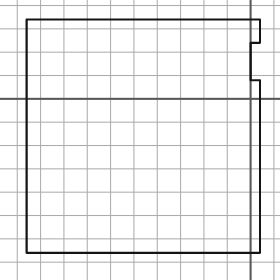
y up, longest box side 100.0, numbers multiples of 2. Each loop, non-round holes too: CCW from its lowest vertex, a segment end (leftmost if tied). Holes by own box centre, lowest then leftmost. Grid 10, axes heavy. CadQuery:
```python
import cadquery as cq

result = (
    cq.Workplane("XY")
    .moveTo(-96.0, -66.0)
    .lineTo(4.0, -66.0)
    .lineTo(4.0, 8.0)
    .lineTo(0.0, 8.0)
    .lineTo(0.0, 24.0)
    .lineTo(4.0, 24.0)
    .lineTo(4.0, 34.0)
    .lineTo(-96.0, 34.0)
    .close()
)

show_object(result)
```